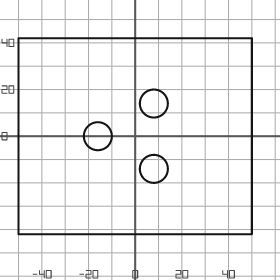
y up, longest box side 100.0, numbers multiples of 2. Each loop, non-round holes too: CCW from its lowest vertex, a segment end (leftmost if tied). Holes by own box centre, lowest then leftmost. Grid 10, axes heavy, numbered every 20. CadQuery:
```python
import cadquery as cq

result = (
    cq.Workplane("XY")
    .moveTo(-50.0, -42.0)
    .lineTo(50.0, -42.0)
    .lineTo(50.0, 42.0)
    .lineTo(-50.0, 42.0)
    .close()
    .moveTo(8.0, -14.0)
    .circle(6.0)
    .moveTo(-16.0, 0.0)
    .circle(6.0)
    .moveTo(8.0, 14.0)
    .circle(6.0)
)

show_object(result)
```